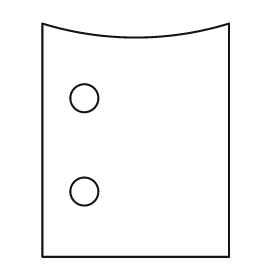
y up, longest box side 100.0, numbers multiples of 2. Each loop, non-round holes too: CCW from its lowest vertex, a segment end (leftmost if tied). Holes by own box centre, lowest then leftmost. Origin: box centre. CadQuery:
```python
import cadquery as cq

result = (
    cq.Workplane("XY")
    .moveTo(-40.0, -50.0)
    .lineTo(40.0, -50.0)
    .lineTo(40.0, 50.0)
    .threePointArc((0.0, 44.0), (-40.0, 50.0))
    .close()
    .moveTo(-22.0, -22.0)
    .circle(6.0)
    .moveTo(-22.0, 18.0)
    .circle(6.0)
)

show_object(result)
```